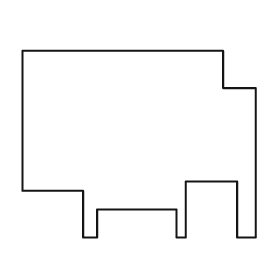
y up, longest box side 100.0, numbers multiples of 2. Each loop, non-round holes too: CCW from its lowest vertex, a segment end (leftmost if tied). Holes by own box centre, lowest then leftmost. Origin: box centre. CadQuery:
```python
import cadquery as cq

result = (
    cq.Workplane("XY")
    .moveTo(-24.0, -40.0)
    .lineTo(-18.0, -40.0)
    .lineTo(-18.0, -28.0)
    .lineTo(16.0, -28.0)
    .lineTo(16.0, -40.0)
    .lineTo(20.0, -40.0)
    .lineTo(20.0, -16.0)
    .lineTo(42.0, -16.0)
    .lineTo(42.0, -40.0)
    .lineTo(50.0, -40.0)
    .lineTo(50.0, 24.0)
    .lineTo(36.0, 24.0)
    .lineTo(36.0, 40.0)
    .lineTo(-50.0, 40.0)
    .lineTo(-50.0, -20.0)
    .lineTo(-24.0, -20.0)
    .close()
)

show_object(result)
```